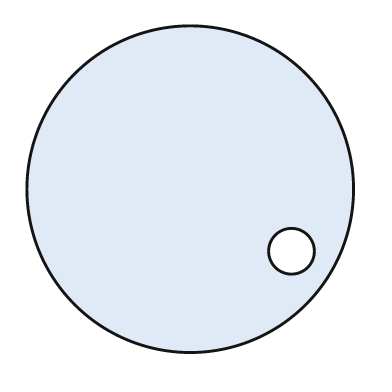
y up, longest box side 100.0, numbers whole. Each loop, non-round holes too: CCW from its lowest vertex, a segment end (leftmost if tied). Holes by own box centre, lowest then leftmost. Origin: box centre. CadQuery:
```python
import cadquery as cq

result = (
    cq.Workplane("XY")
    .moveTo(0.0, 0.0)
    .circle(50.0)
    .moveTo(31.0, -19.0)
    .circle(7.0)
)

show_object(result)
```